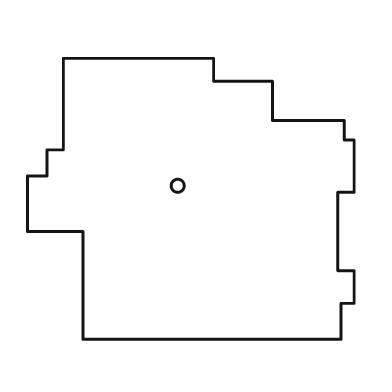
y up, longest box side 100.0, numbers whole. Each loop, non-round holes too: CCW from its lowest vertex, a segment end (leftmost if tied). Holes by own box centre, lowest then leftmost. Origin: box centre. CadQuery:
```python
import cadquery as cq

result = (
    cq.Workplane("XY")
    .moveTo(-33.0, -43.0)
    .lineTo(46.0, -43.0)
    .lineTo(46.0, -32.0)
    .lineTo(50.0, -32.0)
    .lineTo(50.0, -22.0)
    .lineTo(45.0, -22.0)
    .lineTo(45.0, 2.0)
    .lineTo(50.0, 2.0)
    .lineTo(50.0, 18.0)
    .lineTo(47.0, 18.0)
    .lineTo(47.0, 24.0)
    .lineTo(25.0, 24.0)
    .lineTo(25.0, 36.0)
    .lineTo(7.0, 36.0)
    .lineTo(7.0, 43.0)
    .lineTo(-39.0, 43.0)
    .lineTo(-39.0, 15.0)
    .lineTo(-44.0, 15.0)
    .lineTo(-44.0, 7.0)
    .lineTo(-50.0, 7.0)
    .lineTo(-50.0, -10.0)
    .lineTo(-33.0, -10.0)
    .close()
    .moveTo(-4.0, 4.0)
    .circle(2.0)
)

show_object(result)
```